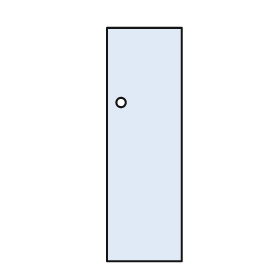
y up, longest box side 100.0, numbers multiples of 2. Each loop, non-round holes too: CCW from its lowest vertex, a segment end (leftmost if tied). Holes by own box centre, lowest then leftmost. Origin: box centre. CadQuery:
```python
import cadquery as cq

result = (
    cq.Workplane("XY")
    .moveTo(-16.0, -50.0)
    .lineTo(16.0, -50.0)
    .lineTo(16.0, 50.0)
    .lineTo(-16.0, 50.0)
    .close()
    .moveTo(-10.0, 18.0)
    .circle(2.0)
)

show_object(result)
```